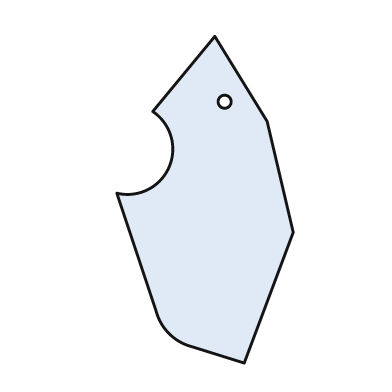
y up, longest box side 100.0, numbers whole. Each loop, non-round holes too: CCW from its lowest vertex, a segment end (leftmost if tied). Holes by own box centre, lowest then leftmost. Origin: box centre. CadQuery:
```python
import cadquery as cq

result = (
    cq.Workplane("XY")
    .moveTo(12.0, -50.0)
    .lineTo(27.0, -10.0)
    .lineTo(19.0, 24.0)
    .lineTo(3.0, 50.0)
    .lineTo(-16.0, 27.0)
    .threePointArc((-11.0, 10.0), (-27.0, 2.0))
    .lineTo(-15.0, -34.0)
    .threePointArc((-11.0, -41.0), (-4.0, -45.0))
    .close()
    .moveTo(6.0, 30.0)
    .circle(2.0)
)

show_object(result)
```